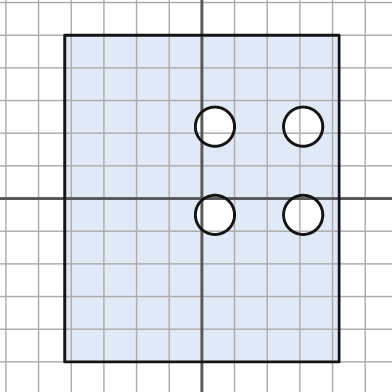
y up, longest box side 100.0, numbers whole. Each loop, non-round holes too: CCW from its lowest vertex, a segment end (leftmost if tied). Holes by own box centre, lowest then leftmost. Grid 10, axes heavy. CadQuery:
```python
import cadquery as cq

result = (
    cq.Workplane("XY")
    .moveTo(-42.0, -50.0)
    .lineTo(42.0, -50.0)
    .lineTo(42.0, 50.0)
    .lineTo(-42.0, 50.0)
    .close()
    .moveTo(4.0, -5.0)
    .circle(6.0)
    .moveTo(31.0, -5.0)
    .circle(6.0)
    .moveTo(4.0, 22.0)
    .circle(6.0)
    .moveTo(31.0, 22.0)
    .circle(6.0)
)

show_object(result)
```